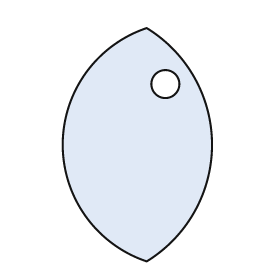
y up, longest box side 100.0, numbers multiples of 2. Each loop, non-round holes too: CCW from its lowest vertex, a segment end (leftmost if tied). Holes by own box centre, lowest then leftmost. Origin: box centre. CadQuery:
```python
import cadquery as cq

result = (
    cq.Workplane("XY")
    .moveTo(4.0, -50.0)
    .threePointArc((32.0, 0.0), (4.0, 50.0))
    .threePointArc((-32.0, 0.0), (4.0, -50.0))
    .close()
    .moveTo(12.0, 26.0)
    .circle(6.0)
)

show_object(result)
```